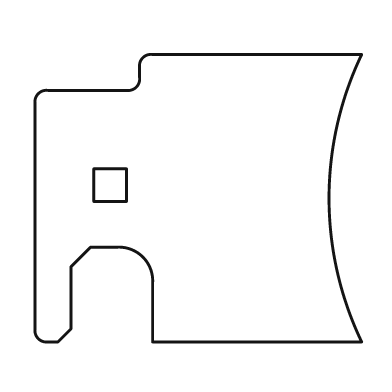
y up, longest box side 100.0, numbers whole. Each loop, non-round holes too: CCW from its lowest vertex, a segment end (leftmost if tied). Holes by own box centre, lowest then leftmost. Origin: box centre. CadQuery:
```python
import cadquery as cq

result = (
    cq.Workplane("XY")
    .moveTo(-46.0, -44.0)
    .lineTo(-43.0, -44.0)
    .lineTo(-39.0, -40.0)
    .lineTo(-39.0, -21.0)
    .lineTo(-33.0, -15.0)
    .lineTo(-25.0, -15.0)
    .threePointArc((-17.0, -18.0), (-14.0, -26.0))
    .lineTo(-14.0, -44.0)
    .lineTo(50.0, -44.0)
    .threePointArc((40.0, 0.0), (50.0, 44.0))
    .lineTo(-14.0, 44.0)
    .threePointArc((-17.0, 43.0), (-18.0, 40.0))
    .lineTo(-18.0, 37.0)
    .threePointArc((-19.0, 34.0), (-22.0, 33.0))
    .lineTo(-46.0, 33.0)
    .threePointArc((-49.0, 32.0), (-50.0, 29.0))
    .lineTo(-50.0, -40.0)
    .threePointArc((-49.0, -43.0), (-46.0, -44.0))
    .close()
    .moveTo(-32.0, -1.0)
    .lineTo(-22.0, -1.0)
    .lineTo(-22.0, 9.0)
    .lineTo(-32.0, 9.0)
    .close()
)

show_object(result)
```